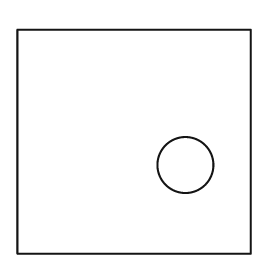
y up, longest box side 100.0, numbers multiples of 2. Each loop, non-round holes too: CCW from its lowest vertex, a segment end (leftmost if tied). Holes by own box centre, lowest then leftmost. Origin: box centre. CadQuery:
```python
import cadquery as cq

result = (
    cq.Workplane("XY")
    .moveTo(-50.0, -48.0)
    .lineTo(50.0, -48.0)
    .lineTo(50.0, 48.0)
    .lineTo(-50.0, 48.0)
    .close()
    .moveTo(22.0, -10.0)
    .circle(12.0)
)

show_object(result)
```